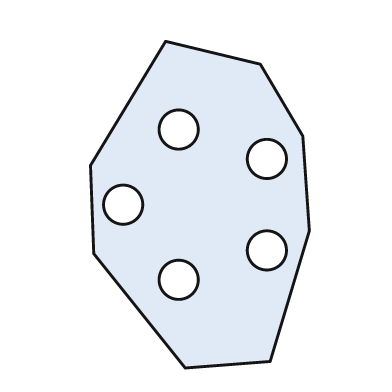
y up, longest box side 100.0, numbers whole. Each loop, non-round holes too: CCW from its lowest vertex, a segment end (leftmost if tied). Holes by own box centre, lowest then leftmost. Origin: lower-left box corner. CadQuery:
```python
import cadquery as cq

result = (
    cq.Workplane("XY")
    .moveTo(29.0, 0.0)
    .lineTo(55.0, 2.0)
    .lineTo(67.0, 42.0)
    .lineTo(65.0, 71.0)
    .lineTo(52.0, 93.0)
    .lineTo(23.0, 100.0)
    .lineTo(0.0, 62.0)
    .lineTo(1.0, 35.0)
    .close()
    .moveTo(27.0, 27.0)
    .circle(6.0)
    .moveTo(54.0, 36.0)
    .circle(6.0)
    .moveTo(10.0, 50.0)
    .circle(6.0)
    .moveTo(54.0, 64.0)
    .circle(6.0)
    .moveTo(27.0, 73.0)
    .circle(6.0)
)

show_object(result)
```